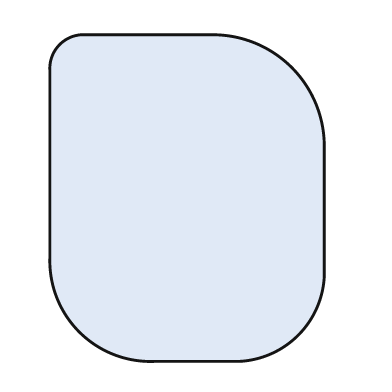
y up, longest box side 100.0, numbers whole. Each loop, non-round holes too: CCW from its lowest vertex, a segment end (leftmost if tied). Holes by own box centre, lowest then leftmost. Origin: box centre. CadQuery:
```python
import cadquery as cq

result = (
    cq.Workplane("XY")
    .moveTo(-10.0, -50.0)
    .lineTo(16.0, -50.0)
    .threePointArc((34.0, -42.0), (42.0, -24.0))
    .lineTo(42.0, 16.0)
    .threePointArc((32.0, 40.0), (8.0, 50.0))
    .lineTo(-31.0, 50.0)
    .threePointArc((-39.0, 47.0), (-42.0, 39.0))
    .lineTo(-42.0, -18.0)
    .threePointArc((-33.0, -41.0), (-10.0, -50.0))
    .close()
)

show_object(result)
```